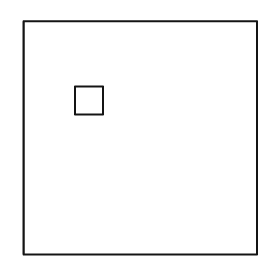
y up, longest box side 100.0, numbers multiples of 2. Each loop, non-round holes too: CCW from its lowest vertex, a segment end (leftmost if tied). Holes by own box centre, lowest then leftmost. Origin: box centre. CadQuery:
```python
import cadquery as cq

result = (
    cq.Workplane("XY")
    .moveTo(-50.0, -50.0)
    .lineTo(50.0, -50.0)
    .lineTo(50.0, 50.0)
    .lineTo(-50.0, 50.0)
    .close()
    .moveTo(-28.0, 10.0)
    .lineTo(-16.0, 10.0)
    .lineTo(-16.0, 22.0)
    .lineTo(-28.0, 22.0)
    .close()
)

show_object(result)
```